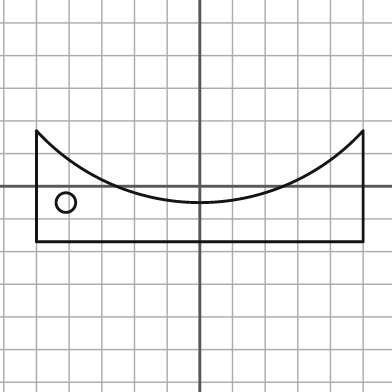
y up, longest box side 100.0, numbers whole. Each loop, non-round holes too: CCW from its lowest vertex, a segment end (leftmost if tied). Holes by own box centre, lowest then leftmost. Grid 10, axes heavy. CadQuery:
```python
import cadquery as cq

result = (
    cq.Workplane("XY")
    .moveTo(-50.0, -17.0)
    .lineTo(50.0, -17.0)
    .lineTo(50.0, 17.0)
    .threePointArc((0.0, -5.0), (-50.0, 17.0))
    .close()
    .moveTo(-41.0, -5.0)
    .circle(3.0)
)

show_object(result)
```